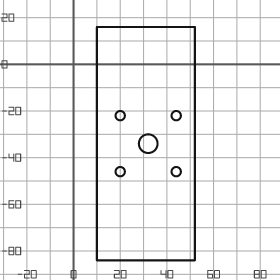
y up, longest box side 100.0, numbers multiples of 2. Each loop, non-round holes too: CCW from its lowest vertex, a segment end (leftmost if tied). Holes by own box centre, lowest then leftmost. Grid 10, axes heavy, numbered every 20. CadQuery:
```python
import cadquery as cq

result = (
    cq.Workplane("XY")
    .moveTo(10.0, -84.0)
    .lineTo(52.0, -84.0)
    .lineTo(52.0, 16.0)
    .lineTo(10.0, 16.0)
    .close()
    .moveTo(20.0, -46.0)
    .circle(2.0)
    .moveTo(44.0, -46.0)
    .circle(2.0)
    .moveTo(32.0, -34.0)
    .circle(4.0)
    .moveTo(20.0, -22.0)
    .circle(2.0)
    .moveTo(44.0, -22.0)
    .circle(2.0)
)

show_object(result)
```